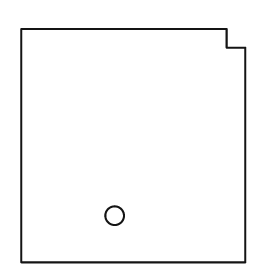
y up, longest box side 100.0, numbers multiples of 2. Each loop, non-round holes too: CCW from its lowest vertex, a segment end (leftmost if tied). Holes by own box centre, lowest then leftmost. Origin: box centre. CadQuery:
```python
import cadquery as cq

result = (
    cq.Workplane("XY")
    .moveTo(-48.0, -50.0)
    .lineTo(48.0, -50.0)
    .lineTo(48.0, 42.0)
    .lineTo(40.0, 42.0)
    .lineTo(40.0, 50.0)
    .lineTo(-48.0, 50.0)
    .close()
    .moveTo(-8.0, -30.0)
    .circle(4.0)
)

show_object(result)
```